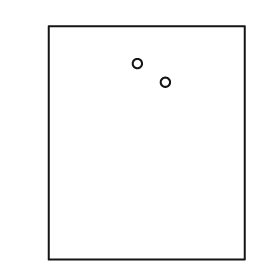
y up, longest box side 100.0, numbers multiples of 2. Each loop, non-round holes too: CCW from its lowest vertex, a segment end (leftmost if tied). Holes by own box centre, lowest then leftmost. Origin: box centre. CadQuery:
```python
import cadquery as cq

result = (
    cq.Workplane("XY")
    .moveTo(-42.0, -50.0)
    .lineTo(42.0, -50.0)
    .lineTo(42.0, 50.0)
    .lineTo(-42.0, 50.0)
    .close()
    .moveTo(8.0, 26.0)
    .circle(2.0)
    .moveTo(-4.0, 34.0)
    .circle(2.0)
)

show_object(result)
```